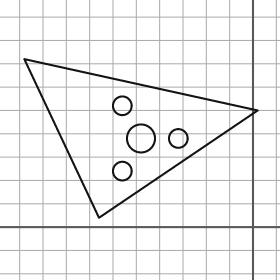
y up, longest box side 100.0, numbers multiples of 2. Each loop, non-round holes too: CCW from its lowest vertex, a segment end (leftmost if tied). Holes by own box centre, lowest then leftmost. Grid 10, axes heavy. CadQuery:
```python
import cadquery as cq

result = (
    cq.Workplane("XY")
    .moveTo(-66.0, 4.0)
    .lineTo(2.0, 50.0)
    .lineTo(-98.0, 72.0)
    .close()
    .moveTo(-56.0, 24.0)
    .circle(4.0)
    .moveTo(-48.0, 38.0)
    .circle(6.0)
    .moveTo(-32.0, 38.0)
    .circle(4.0)
    .moveTo(-56.0, 52.0)
    .circle(4.0)
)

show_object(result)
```